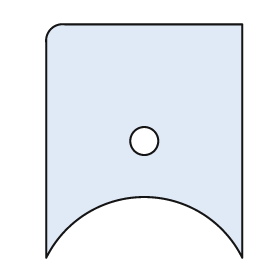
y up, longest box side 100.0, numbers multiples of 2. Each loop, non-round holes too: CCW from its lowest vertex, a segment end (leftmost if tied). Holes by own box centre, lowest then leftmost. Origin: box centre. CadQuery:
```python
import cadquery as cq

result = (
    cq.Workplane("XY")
    .moveTo(-42.0, -50.0)
    .threePointArc((0.0, -24.0), (42.0, -50.0))
    .lineTo(42.0, 50.0)
    .lineTo(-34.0, 50.0)
    .threePointArc((-40.0, 48.0), (-42.0, 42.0))
    .close()
    .moveTo(0.0, 0.0)
    .circle(6.0)
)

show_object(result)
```